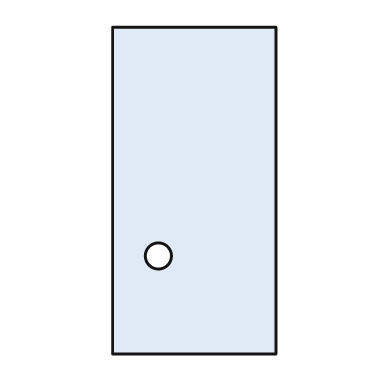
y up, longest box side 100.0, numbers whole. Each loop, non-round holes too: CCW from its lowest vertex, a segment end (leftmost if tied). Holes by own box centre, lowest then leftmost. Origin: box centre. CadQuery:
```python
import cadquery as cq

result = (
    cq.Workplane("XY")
    .moveTo(-25.0, -50.0)
    .lineTo(25.0, -50.0)
    .lineTo(25.0, 50.0)
    .lineTo(-25.0, 50.0)
    .close()
    .moveTo(-11.0, -20.0)
    .circle(4.0)
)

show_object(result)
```